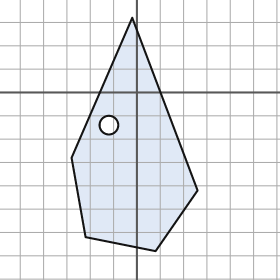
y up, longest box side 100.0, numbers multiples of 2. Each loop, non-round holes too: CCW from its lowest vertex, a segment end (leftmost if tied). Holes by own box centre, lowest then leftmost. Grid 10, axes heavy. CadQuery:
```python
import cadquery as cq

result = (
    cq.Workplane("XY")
    .moveTo(8.0, -68.0)
    .lineTo(26.0, -42.0)
    .lineTo(-2.0, 32.0)
    .lineTo(-28.0, -28.0)
    .lineTo(-22.0, -62.0)
    .close()
    .moveTo(-12.0, -14.0)
    .circle(4.0)
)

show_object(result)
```